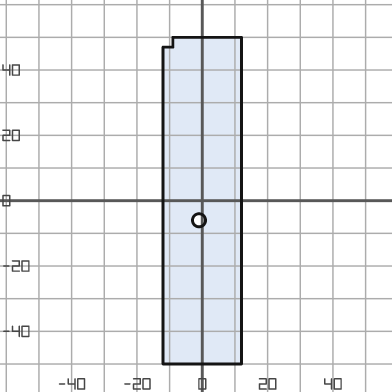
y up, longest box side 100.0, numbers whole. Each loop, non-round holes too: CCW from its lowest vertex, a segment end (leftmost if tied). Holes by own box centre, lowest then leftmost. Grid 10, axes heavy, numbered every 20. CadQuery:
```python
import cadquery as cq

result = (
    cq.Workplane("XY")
    .moveTo(-12.0, -50.0)
    .lineTo(12.0, -50.0)
    .lineTo(12.0, 50.0)
    .lineTo(-9.0, 50.0)
    .lineTo(-9.0, 47.0)
    .lineTo(-12.0, 47.0)
    .close()
    .moveTo(-1.0, -6.0)
    .circle(2.0)
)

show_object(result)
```